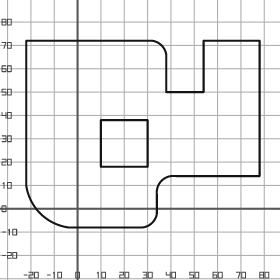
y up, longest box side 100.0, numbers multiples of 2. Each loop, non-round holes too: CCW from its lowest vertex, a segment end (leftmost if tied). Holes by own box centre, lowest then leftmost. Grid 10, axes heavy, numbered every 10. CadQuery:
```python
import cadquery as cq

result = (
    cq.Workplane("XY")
    .moveTo(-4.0, -8.0)
    .lineTo(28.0, -8.0)
    .threePointArc((32.0, -6.0), (34.0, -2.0))
    .lineTo(34.0, 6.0)
    .threePointArc((36.0, 12.0), (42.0, 14.0))
    .lineTo(78.0, 14.0)
    .lineTo(78.0, 72.0)
    .lineTo(54.0, 72.0)
    .lineTo(54.0, 50.0)
    .lineTo(38.0, 50.0)
    .lineTo(38.0, 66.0)
    .threePointArc((36.0, 70.0), (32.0, 72.0))
    .lineTo(-22.0, 72.0)
    .lineTo(-22.0, 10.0)
    .threePointArc((-16.0, -2.0), (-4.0, -8.0))
    .close()
    .moveTo(10.0, 18.0)
    .lineTo(30.0, 18.0)
    .lineTo(30.0, 38.0)
    .lineTo(10.0, 38.0)
    .close()
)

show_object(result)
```